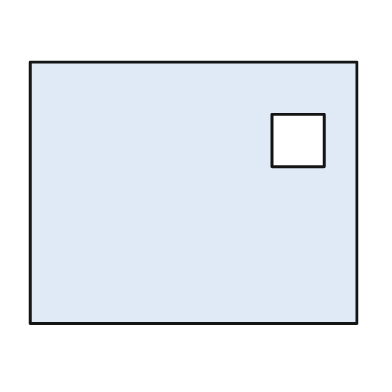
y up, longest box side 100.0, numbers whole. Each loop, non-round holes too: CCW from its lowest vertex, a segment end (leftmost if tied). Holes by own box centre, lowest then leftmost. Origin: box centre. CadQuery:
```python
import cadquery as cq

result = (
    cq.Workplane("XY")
    .moveTo(-50.0, -40.0)
    .lineTo(50.0, -40.0)
    .lineTo(50.0, 40.0)
    .lineTo(-50.0, 40.0)
    .close()
    .moveTo(24.0, 8.0)
    .lineTo(40.0, 8.0)
    .lineTo(40.0, 24.0)
    .lineTo(24.0, 24.0)
    .close()
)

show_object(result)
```